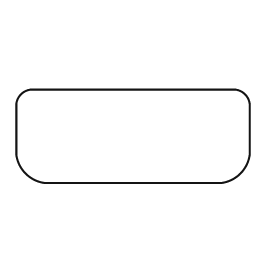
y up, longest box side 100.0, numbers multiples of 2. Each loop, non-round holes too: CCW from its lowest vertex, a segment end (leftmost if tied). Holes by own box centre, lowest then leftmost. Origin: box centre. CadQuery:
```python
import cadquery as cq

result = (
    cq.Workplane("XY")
    .moveTo(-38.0, -20.0)
    .lineTo(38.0, -20.0)
    .threePointArc((46.0, -16.0), (50.0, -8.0))
    .lineTo(50.0, 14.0)
    .threePointArc((48.0, 18.0), (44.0, 20.0))
    .lineTo(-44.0, 20.0)
    .threePointArc((-48.0, 18.0), (-50.0, 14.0))
    .lineTo(-50.0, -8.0)
    .threePointArc((-46.0, -16.0), (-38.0, -20.0))
    .close()
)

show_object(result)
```